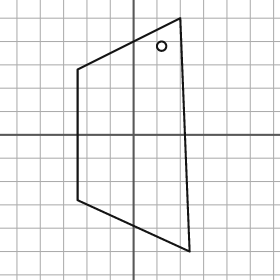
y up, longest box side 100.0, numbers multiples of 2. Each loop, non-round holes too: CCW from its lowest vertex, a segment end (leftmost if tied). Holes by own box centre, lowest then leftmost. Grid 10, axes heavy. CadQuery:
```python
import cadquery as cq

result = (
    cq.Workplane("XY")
    .moveTo(24.0, -50.0)
    .lineTo(20.0, 50.0)
    .lineTo(-24.0, 28.0)
    .lineTo(-24.0, -28.0)
    .close()
    .moveTo(12.0, 38.0)
    .circle(2.0)
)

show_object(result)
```